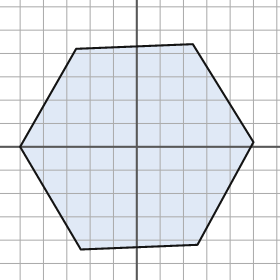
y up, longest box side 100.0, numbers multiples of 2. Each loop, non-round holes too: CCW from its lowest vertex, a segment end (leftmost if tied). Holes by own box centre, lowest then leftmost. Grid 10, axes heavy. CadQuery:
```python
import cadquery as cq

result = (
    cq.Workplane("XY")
    .moveTo(-24.0, -44.0)
    .lineTo(26.0, -42.0)
    .lineTo(50.0, 2.0)
    .lineTo(24.0, 44.0)
    .lineTo(-26.0, 42.0)
    .lineTo(-50.0, 0.0)
    .close()
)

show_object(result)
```